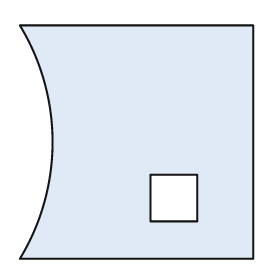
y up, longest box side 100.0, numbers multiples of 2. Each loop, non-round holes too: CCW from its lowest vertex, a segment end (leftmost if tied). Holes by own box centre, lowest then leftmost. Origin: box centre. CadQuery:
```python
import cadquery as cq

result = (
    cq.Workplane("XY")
    .moveTo(-50.0, -50.0)
    .lineTo(50.0, -50.0)
    .lineTo(50.0, 50.0)
    .lineTo(-50.0, 50.0)
    .threePointArc((-36.0, 0.0), (-50.0, -50.0))
    .close()
    .moveTo(6.0, -34.0)
    .lineTo(26.0, -34.0)
    .lineTo(26.0, -14.0)
    .lineTo(6.0, -14.0)
    .close()
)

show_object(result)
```